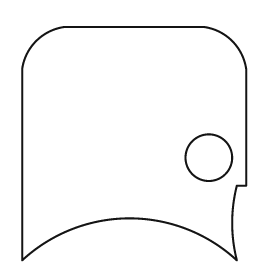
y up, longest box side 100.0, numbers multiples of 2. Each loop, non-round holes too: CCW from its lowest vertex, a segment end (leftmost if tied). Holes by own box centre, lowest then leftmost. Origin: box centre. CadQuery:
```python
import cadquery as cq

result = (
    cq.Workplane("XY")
    .moveTo(-48.0, -50.0)
    .threePointArc((-2.0, -32.0), (44.0, -50.0))
    .threePointArc((42.0, -34.0), (44.0, -18.0))
    .lineTo(48.0, -18.0)
    .lineTo(48.0, 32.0)
    .threePointArc((42.0, 44.0), (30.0, 50.0))
    .lineTo(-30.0, 50.0)
    .threePointArc((-42.0, 44.0), (-48.0, 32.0))
    .close()
    .moveTo(32.0, -6.0)
    .circle(10.0)
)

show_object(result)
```